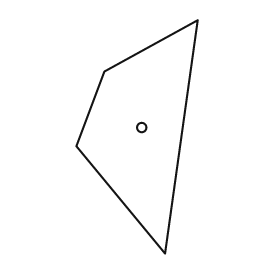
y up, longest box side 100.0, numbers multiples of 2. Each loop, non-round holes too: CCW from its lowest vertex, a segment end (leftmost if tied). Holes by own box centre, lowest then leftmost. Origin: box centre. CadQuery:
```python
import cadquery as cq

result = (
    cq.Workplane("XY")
    .moveTo(12.0, -50.0)
    .lineTo(26.0, 50.0)
    .lineTo(-14.0, 28.0)
    .lineTo(-26.0, -4.0)
    .close()
    .moveTo(2.0, 4.0)
    .circle(2.0)
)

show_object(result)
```